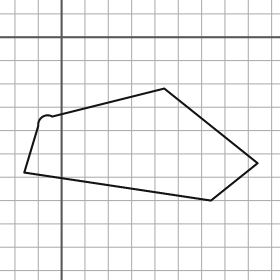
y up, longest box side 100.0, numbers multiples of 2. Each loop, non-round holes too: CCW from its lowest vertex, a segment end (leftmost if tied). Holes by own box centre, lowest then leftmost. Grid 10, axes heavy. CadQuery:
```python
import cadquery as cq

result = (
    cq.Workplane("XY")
    .moveTo(64.0, -70.0)
    .lineTo(84.0, -54.0)
    .lineTo(44.0, -22.0)
    .lineTo(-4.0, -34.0)
    .threePointArc((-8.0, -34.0), (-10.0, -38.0))
    .lineTo(-16.0, -58.0)
    .close()
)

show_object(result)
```